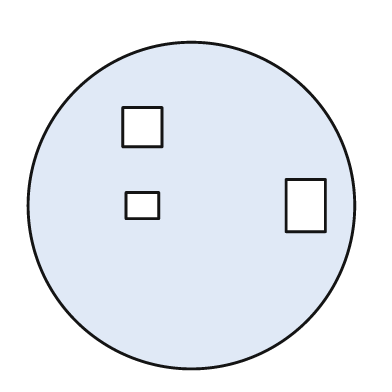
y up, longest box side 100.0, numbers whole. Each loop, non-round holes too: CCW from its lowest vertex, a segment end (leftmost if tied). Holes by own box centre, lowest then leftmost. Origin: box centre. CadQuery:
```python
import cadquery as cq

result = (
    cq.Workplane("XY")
    .moveTo(0.0, 0.0)
    .circle(50.0)
    .moveTo(-20.0, -4.0)
    .lineTo(-10.0, -4.0)
    .lineTo(-10.0, 4.0)
    .lineTo(-20.0, 4.0)
    .close()
    .moveTo(29.0, -8.0)
    .lineTo(41.0, -8.0)
    .lineTo(41.0, 8.0)
    .lineTo(29.0, 8.0)
    .close()
    .moveTo(-21.0, 18.0)
    .lineTo(-9.0, 18.0)
    .lineTo(-9.0, 30.0)
    .lineTo(-21.0, 30.0)
    .close()
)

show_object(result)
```